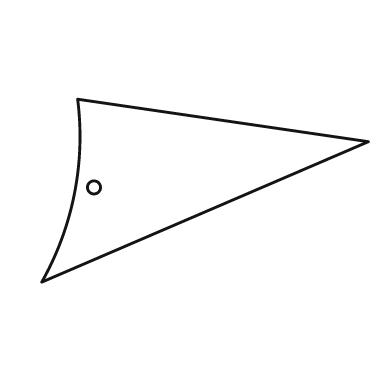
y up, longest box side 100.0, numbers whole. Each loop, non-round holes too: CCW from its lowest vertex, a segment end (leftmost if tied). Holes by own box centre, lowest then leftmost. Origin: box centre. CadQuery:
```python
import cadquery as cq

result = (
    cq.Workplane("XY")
    .moveTo(-50.0, -28.0)
    .lineTo(50.0, 15.0)
    .lineTo(-39.0, 28.0)
    .threePointArc((-40.0, -1.0), (-50.0, -28.0))
    .close()
    .moveTo(-34.0, 1.0)
    .circle(2.0)
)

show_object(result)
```